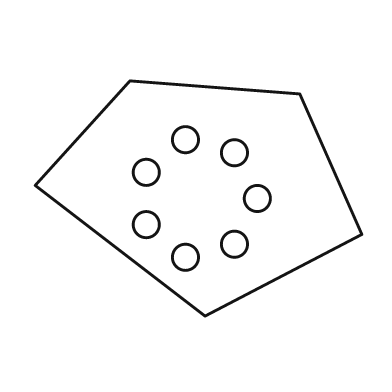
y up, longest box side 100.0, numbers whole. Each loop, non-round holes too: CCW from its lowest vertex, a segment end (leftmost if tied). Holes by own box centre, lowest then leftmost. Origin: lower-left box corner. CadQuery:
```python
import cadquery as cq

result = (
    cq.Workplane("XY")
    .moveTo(52.0, 0.0)
    .lineTo(100.0, 25.0)
    .lineTo(81.0, 68.0)
    .lineTo(29.0, 72.0)
    .lineTo(0.0, 40.0)
    .close()
    .moveTo(46.0, 18.0)
    .circle(4.0)
    .moveTo(61.0, 22.0)
    .circle(4.0)
    .moveTo(34.0, 28.0)
    .circle(4.0)
    .moveTo(68.0, 36.0)
    .circle(4.0)
    .moveTo(34.0, 44.0)
    .circle(4.0)
    .moveTo(61.0, 50.0)
    .circle(4.0)
    .moveTo(46.0, 54.0)
    .circle(4.0)
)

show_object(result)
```